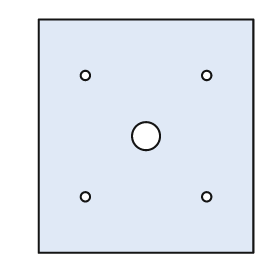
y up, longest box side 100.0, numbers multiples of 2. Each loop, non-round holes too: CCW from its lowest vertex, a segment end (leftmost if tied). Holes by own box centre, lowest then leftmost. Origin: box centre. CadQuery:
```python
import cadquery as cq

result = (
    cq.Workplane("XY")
    .moveTo(-46.0, -50.0)
    .lineTo(46.0, -50.0)
    .lineTo(46.0, 50.0)
    .lineTo(-46.0, 50.0)
    .close()
    .moveTo(-26.0, -26.0)
    .circle(2.0)
    .moveTo(26.0, -26.0)
    .circle(2.0)
    .moveTo(0.0, 0.0)
    .circle(6.0)
    .moveTo(-26.0, 26.0)
    .circle(2.0)
    .moveTo(26.0, 26.0)
    .circle(2.0)
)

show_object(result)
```